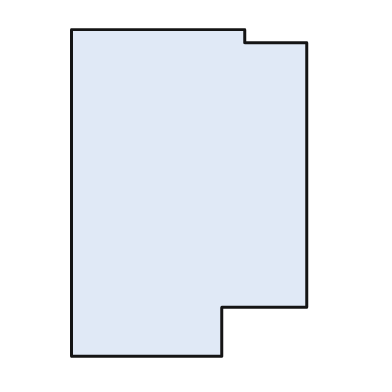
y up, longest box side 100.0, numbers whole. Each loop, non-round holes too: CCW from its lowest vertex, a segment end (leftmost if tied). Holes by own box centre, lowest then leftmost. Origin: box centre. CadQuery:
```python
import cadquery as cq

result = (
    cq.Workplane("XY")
    .moveTo(-36.0, -50.0)
    .lineTo(10.0, -50.0)
    .lineTo(10.0, -35.0)
    .lineTo(36.0, -35.0)
    .lineTo(36.0, 46.0)
    .lineTo(17.0, 46.0)
    .lineTo(17.0, 50.0)
    .lineTo(-36.0, 50.0)
    .close()
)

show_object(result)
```